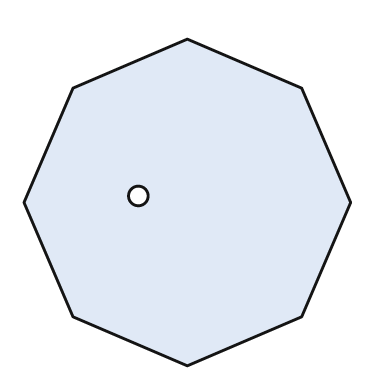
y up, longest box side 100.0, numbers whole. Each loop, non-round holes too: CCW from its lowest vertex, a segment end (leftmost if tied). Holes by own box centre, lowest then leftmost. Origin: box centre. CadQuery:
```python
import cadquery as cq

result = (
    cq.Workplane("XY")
    .moveTo(0.0, -50.0)
    .lineTo(35.0, -35.0)
    .lineTo(50.0, 0.0)
    .lineTo(35.0, 35.0)
    .lineTo(0.0, 50.0)
    .lineTo(-35.0, 35.0)
    .lineTo(-50.0, 0.0)
    .lineTo(-35.0, -35.0)
    .close()
    .moveTo(-15.0, 2.0)
    .circle(3.0)
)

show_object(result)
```